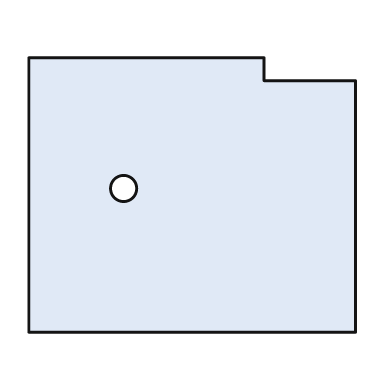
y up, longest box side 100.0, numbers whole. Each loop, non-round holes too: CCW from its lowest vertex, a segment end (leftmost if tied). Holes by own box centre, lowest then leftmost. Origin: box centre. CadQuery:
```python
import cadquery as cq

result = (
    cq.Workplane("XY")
    .moveTo(-50.0, -42.0)
    .lineTo(50.0, -42.0)
    .lineTo(50.0, 35.0)
    .lineTo(22.0, 35.0)
    .lineTo(22.0, 42.0)
    .lineTo(-50.0, 42.0)
    .close()
    .moveTo(-21.0, 2.0)
    .circle(4.0)
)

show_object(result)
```